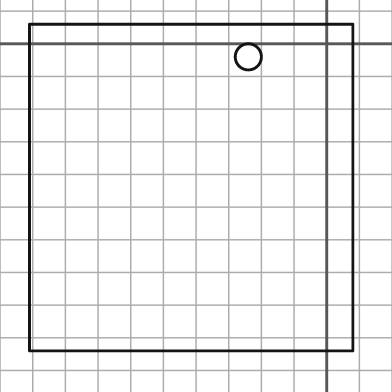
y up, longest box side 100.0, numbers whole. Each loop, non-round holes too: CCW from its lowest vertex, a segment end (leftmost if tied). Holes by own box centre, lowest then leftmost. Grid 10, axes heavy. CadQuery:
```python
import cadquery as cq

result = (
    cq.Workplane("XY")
    .moveTo(-91.0, -94.0)
    .lineTo(8.0, -94.0)
    .lineTo(8.0, 6.0)
    .lineTo(-91.0, 6.0)
    .close()
    .moveTo(-24.0, -4.0)
    .circle(4.0)
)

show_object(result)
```